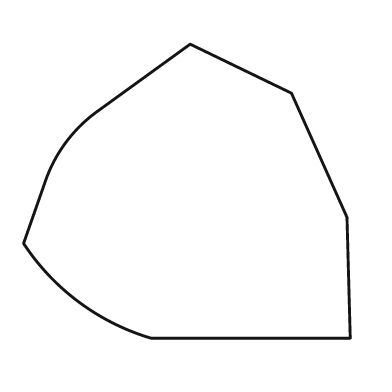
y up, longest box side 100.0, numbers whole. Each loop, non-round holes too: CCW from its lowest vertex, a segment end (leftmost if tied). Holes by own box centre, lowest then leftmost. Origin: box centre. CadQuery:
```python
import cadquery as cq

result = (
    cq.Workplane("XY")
    .moveTo(-11.0, -45.0)
    .lineTo(50.0, -45.0)
    .lineTo(49.0, -8.0)
    .lineTo(32.0, 30.0)
    .lineTo(1.0, 45.0)
    .lineTo(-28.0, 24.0)
    .threePointArc((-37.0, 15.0), (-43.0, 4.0))
    .lineTo(-50.0, -16.0)
    .threePointArc((-33.0, -34.0), (-11.0, -45.0))
    .close()
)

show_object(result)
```